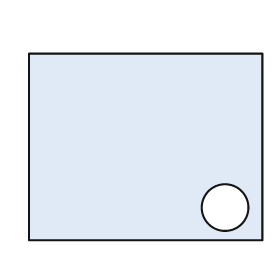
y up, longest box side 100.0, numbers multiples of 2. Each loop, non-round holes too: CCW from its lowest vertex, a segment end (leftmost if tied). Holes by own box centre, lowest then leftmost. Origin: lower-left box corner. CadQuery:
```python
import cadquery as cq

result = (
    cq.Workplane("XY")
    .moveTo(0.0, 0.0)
    .lineTo(100.0, 0.0)
    .lineTo(100.0, 80.0)
    .lineTo(0.0, 80.0)
    .close()
    .moveTo(84.0, 14.0)
    .circle(10.0)
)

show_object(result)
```